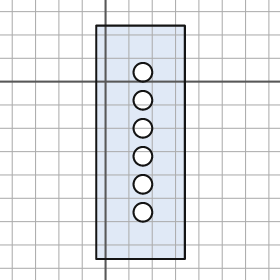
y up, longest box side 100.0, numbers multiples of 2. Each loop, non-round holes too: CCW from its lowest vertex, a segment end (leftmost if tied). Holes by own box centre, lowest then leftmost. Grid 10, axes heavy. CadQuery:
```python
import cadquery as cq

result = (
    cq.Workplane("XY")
    .moveTo(-4.0, -76.0)
    .lineTo(34.0, -76.0)
    .lineTo(34.0, 24.0)
    .lineTo(-4.0, 24.0)
    .close()
    .moveTo(16.0, -56.0)
    .circle(4.0)
    .moveTo(16.0, -44.0)
    .circle(4.0)
    .moveTo(16.0, -32.0)
    .circle(4.0)
    .moveTo(16.0, -20.0)
    .circle(4.0)
    .moveTo(16.0, -8.0)
    .circle(4.0)
    .moveTo(16.0, 4.0)
    .circle(4.0)
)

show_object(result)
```